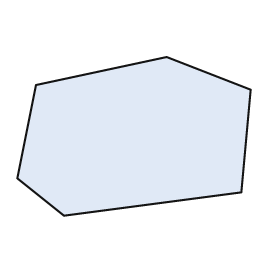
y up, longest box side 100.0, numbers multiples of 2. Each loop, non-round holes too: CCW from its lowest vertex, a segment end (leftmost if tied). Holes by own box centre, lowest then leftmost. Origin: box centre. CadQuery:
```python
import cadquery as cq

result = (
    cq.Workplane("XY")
    .moveTo(-30.0, -34.0)
    .lineTo(46.0, -24.0)
    .lineTo(50.0, 20.0)
    .lineTo(14.0, 34.0)
    .lineTo(-42.0, 22.0)
    .lineTo(-50.0, -18.0)
    .close()
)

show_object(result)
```